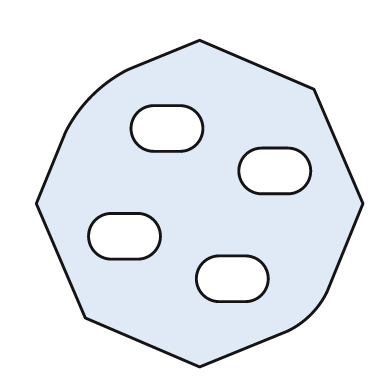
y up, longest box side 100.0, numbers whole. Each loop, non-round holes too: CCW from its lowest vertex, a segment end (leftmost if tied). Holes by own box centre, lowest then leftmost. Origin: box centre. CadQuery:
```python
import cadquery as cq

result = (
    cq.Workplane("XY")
    .moveTo(0.0, -50.0)
    .lineTo(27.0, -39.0)
    .threePointArc((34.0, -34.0), (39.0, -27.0))
    .lineTo(50.0, 0.0)
    .lineTo(35.0, 35.0)
    .lineTo(0.0, 50.0)
    .lineTo(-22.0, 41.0)
    .threePointArc((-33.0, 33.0), (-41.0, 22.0))
    .lineTo(-50.0, 0.0)
    .lineTo(-35.0, -35.0)
    .close()
    .moveTo(6.0, -30.0)
    .lineTo(14.0, -30.0)
    .threePointArc((21.0, -23.0), (14.0, -16.0))
    .lineTo(6.0, -16.0)
    .threePointArc((-1.0, -23.0), (6.0, -30.0))
    .close()
    .moveTo(-27.0, -17.0)
    .lineTo(-19.0, -17.0)
    .threePointArc((-12.0, -10.0), (-19.0, -3.0))
    .lineTo(-27.0, -3.0)
    .threePointArc((-34.0, -10.0), (-27.0, -17.0))
    .close()
    .moveTo(19.0, 3.0)
    .lineTo(27.0, 3.0)
    .threePointArc((34.0, 10.0), (27.0, 17.0))
    .lineTo(19.0, 17.0)
    .threePointArc((12.0, 10.0), (19.0, 3.0))
    .close()
    .moveTo(-14.0, 16.0)
    .lineTo(-6.0, 16.0)
    .threePointArc((1.0, 23.0), (-6.0, 30.0))
    .lineTo(-14.0, 30.0)
    .threePointArc((-21.0, 23.0), (-14.0, 16.0))
    .close()
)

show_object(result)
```